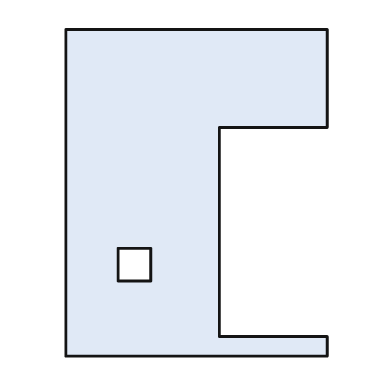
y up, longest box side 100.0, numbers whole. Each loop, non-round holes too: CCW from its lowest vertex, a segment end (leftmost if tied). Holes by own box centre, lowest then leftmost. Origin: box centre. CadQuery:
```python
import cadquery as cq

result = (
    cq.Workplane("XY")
    .moveTo(-40.0, -50.0)
    .lineTo(40.0, -50.0)
    .lineTo(40.0, -44.0)
    .lineTo(7.0, -44.0)
    .lineTo(7.0, 20.0)
    .lineTo(40.0, 20.0)
    .lineTo(40.0, 50.0)
    .lineTo(-40.0, 50.0)
    .close()
    .moveTo(-24.0, -27.0)
    .lineTo(-14.0, -27.0)
    .lineTo(-14.0, -17.0)
    .lineTo(-24.0, -17.0)
    .close()
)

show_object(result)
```